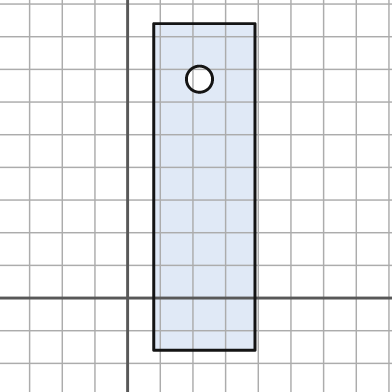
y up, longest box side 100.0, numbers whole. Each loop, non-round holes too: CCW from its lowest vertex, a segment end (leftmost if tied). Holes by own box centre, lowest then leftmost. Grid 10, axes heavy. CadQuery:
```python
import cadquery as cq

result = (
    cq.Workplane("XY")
    .moveTo(8.0, -16.0)
    .lineTo(39.0, -16.0)
    .lineTo(39.0, 84.0)
    .lineTo(8.0, 84.0)
    .close()
    .moveTo(22.0, 67.0)
    .circle(4.0)
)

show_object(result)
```